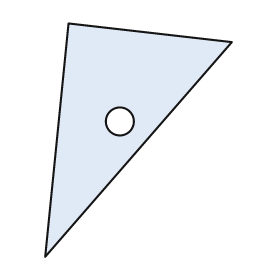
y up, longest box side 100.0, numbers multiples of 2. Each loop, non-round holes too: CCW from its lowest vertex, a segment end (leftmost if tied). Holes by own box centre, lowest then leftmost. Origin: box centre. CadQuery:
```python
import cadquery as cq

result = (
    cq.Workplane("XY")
    .moveTo(-40.0, -50.0)
    .lineTo(40.0, 42.0)
    .lineTo(-30.0, 50.0)
    .close()
    .moveTo(-8.0, 8.0)
    .circle(6.0)
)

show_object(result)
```